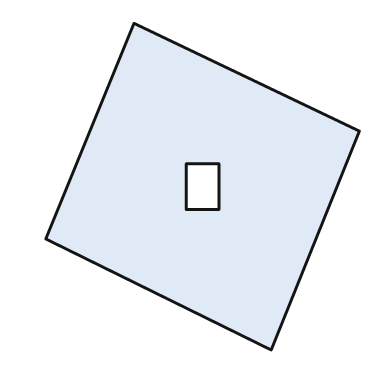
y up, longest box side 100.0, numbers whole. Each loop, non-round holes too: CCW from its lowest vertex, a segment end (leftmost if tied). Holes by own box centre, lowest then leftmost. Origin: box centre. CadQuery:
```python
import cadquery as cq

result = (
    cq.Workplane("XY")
    .moveTo(21.0, -50.0)
    .lineTo(48.0, 17.0)
    .lineTo(-21.0, 50.0)
    .lineTo(-48.0, -16.0)
    .close()
    .moveTo(-5.0, -7.0)
    .lineTo(5.0, -7.0)
    .lineTo(5.0, 7.0)
    .lineTo(-5.0, 7.0)
    .close()
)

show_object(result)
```